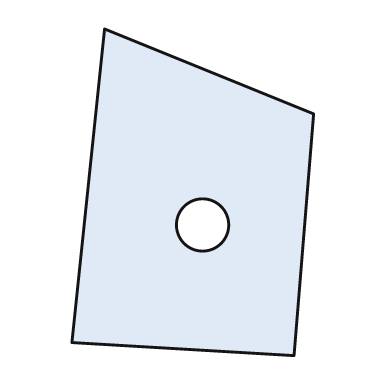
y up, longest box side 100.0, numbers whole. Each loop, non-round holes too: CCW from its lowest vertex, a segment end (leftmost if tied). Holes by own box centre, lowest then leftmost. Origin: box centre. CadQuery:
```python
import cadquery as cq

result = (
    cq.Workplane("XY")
    .moveTo(31.0, -50.0)
    .lineTo(37.0, 24.0)
    .lineTo(-27.0, 50.0)
    .lineTo(-37.0, -46.0)
    .close()
    .moveTo(3.0, -10.0)
    .circle(8.0)
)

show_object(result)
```